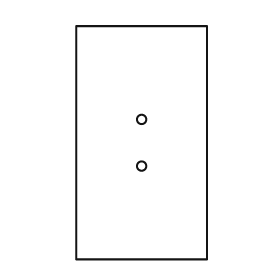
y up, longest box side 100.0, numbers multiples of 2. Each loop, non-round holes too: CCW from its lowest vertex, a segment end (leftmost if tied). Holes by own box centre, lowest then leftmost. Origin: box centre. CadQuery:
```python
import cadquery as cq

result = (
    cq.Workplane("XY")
    .moveTo(-28.0, -50.0)
    .lineTo(28.0, -50.0)
    .lineTo(28.0, 50.0)
    .lineTo(-28.0, 50.0)
    .close()
    .moveTo(0.0, -10.0)
    .circle(2.0)
    .moveTo(0.0, 10.0)
    .circle(2.0)
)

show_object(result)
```